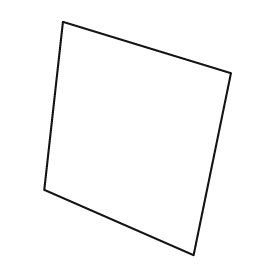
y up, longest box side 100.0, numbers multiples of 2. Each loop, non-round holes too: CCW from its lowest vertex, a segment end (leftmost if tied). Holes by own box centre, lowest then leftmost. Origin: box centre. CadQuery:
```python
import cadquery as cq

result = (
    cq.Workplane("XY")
    .moveTo(24.0, -50.0)
    .lineTo(40.0, 28.0)
    .lineTo(-32.0, 50.0)
    .lineTo(-40.0, -22.0)
    .close()
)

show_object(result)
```